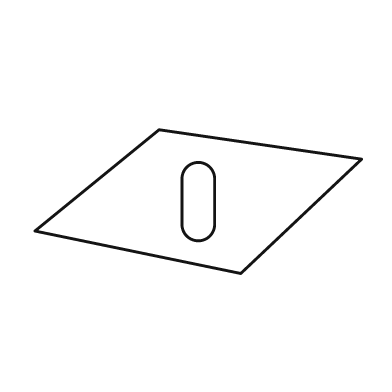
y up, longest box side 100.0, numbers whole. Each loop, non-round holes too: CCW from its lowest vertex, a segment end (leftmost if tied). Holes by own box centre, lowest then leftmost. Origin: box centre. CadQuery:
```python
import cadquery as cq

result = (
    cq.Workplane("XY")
    .moveTo(13.0, -22.0)
    .lineTo(50.0, 13.0)
    .lineTo(-12.0, 22.0)
    .lineTo(-50.0, -9.0)
    .close()
    .moveTo(-5.0, -7.0)
    .threePointArc((0.0, -12.0), (5.0, -7.0))
    .lineTo(5.0, 7.0)
    .threePointArc((0.0, 12.0), (-5.0, 7.0))
    .close()
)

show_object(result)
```